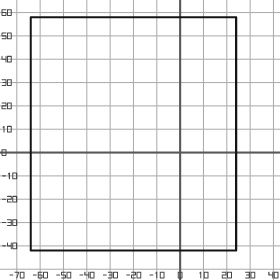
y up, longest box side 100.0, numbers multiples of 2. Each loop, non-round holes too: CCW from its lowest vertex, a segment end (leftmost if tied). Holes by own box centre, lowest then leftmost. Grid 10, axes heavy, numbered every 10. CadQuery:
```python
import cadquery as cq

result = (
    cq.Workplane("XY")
    .moveTo(-64.0, -42.0)
    .lineTo(24.0, -42.0)
    .lineTo(24.0, 58.0)
    .lineTo(-64.0, 58.0)
    .close()
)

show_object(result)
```